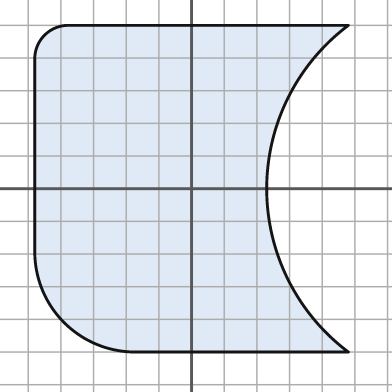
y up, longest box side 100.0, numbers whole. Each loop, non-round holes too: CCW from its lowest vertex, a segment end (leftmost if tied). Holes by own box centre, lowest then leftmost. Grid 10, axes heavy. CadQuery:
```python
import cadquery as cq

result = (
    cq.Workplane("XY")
    .moveTo(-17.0, -50.0)
    .lineTo(48.0, -50.0)
    .threePointArc((23.0, 0.0), (48.0, 50.0))
    .lineTo(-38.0, 50.0)
    .threePointArc((-45.0, 47.0), (-48.0, 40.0))
    .lineTo(-48.0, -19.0)
    .threePointArc((-39.0, -41.0), (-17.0, -50.0))
    .close()
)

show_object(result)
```